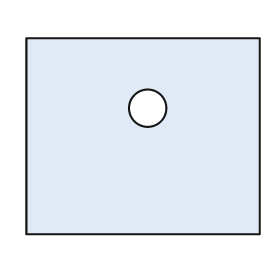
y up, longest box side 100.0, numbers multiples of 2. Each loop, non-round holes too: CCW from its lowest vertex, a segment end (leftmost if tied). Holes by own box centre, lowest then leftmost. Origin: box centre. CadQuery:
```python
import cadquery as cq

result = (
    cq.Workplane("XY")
    .moveTo(-50.0, -42.0)
    .lineTo(50.0, -42.0)
    .lineTo(50.0, 42.0)
    .lineTo(-50.0, 42.0)
    .close()
    .moveTo(2.0, 12.0)
    .circle(8.0)
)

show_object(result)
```